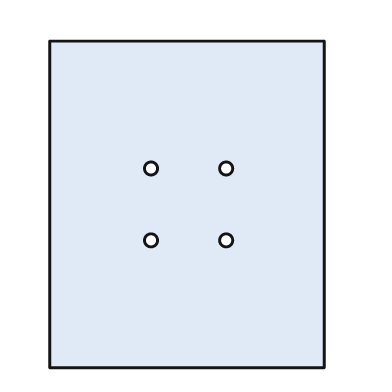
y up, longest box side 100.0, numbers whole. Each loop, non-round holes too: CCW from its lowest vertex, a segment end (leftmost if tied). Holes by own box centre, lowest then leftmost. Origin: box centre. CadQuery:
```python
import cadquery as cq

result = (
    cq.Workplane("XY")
    .moveTo(-42.0, -50.0)
    .lineTo(42.0, -50.0)
    .lineTo(42.0, 50.0)
    .lineTo(-42.0, 50.0)
    .close()
    .moveTo(-11.0, -11.0)
    .circle(2.0)
    .moveTo(12.0, -11.0)
    .circle(2.0)
    .moveTo(-11.0, 11.0)
    .circle(2.0)
    .moveTo(12.0, 11.0)
    .circle(2.0)
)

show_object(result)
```